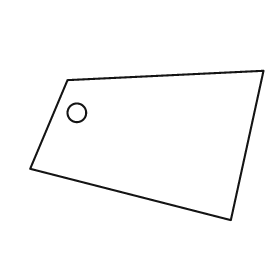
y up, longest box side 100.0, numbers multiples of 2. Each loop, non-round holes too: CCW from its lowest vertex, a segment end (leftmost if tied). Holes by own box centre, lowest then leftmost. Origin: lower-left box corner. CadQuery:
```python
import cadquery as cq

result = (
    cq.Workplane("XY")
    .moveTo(86.0, 0.0)
    .lineTo(100.0, 64.0)
    .lineTo(16.0, 60.0)
    .lineTo(0.0, 22.0)
    .close()
    .moveTo(20.0, 46.0)
    .circle(4.0)
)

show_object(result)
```